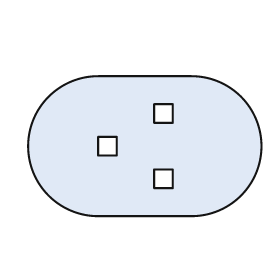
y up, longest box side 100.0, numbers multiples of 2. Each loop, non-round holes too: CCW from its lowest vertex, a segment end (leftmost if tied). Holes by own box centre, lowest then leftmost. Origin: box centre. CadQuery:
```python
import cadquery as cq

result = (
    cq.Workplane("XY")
    .moveTo(-20.0, -30.0)
    .lineTo(20.0, -30.0)
    .threePointArc((50.0, 0.0), (20.0, 30.0))
    .lineTo(-20.0, 30.0)
    .threePointArc((-50.0, 0.0), (-20.0, -30.0))
    .close()
    .moveTo(4.0, -18.0)
    .lineTo(12.0, -18.0)
    .lineTo(12.0, -10.0)
    .lineTo(4.0, -10.0)
    .close()
    .moveTo(-20.0, -4.0)
    .lineTo(-12.0, -4.0)
    .lineTo(-12.0, 4.0)
    .lineTo(-20.0, 4.0)
    .close()
    .moveTo(4.0, 10.0)
    .lineTo(12.0, 10.0)
    .lineTo(12.0, 18.0)
    .lineTo(4.0, 18.0)
    .close()
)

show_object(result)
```